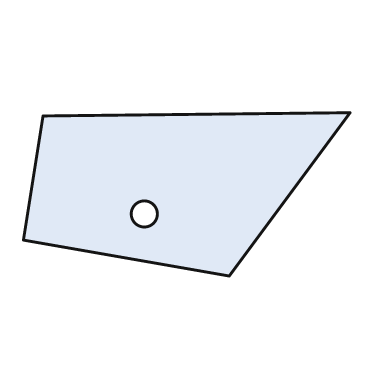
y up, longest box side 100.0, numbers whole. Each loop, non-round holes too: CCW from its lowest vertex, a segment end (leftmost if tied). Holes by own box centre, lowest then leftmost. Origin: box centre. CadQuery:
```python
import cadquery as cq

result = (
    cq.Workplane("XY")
    .moveTo(13.0, -25.0)
    .lineTo(50.0, 25.0)
    .lineTo(-44.0, 24.0)
    .lineTo(-50.0, -14.0)
    .close()
    .moveTo(-13.0, -6.0)
    .circle(4.0)
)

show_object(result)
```